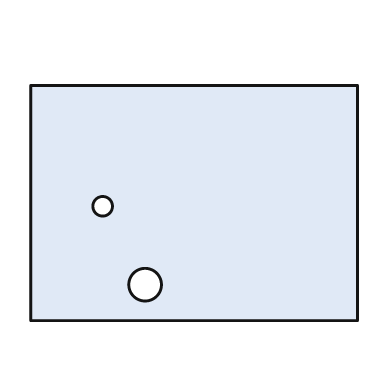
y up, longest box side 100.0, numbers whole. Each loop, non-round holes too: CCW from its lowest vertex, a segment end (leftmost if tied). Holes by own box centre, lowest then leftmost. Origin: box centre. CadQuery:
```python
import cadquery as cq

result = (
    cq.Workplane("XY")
    .moveTo(-50.0, -36.0)
    .lineTo(50.0, -36.0)
    .lineTo(50.0, 36.0)
    .lineTo(-50.0, 36.0)
    .close()
    .moveTo(-15.0, -25.0)
    .circle(5.0)
    .moveTo(-28.0, -1.0)
    .circle(3.0)
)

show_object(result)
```